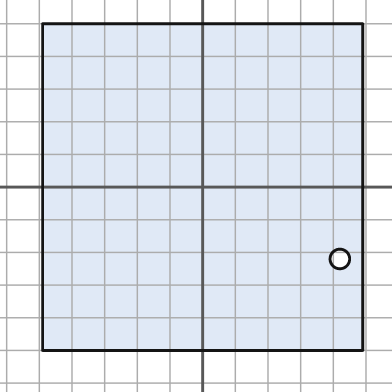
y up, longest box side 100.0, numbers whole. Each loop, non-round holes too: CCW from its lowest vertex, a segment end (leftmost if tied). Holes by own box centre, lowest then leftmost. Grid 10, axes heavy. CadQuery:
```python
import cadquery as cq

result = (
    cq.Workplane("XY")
    .moveTo(-49.0, -50.0)
    .lineTo(49.0, -50.0)
    .lineTo(49.0, 50.0)
    .lineTo(-49.0, 50.0)
    .close()
    .moveTo(42.0, -22.0)
    .circle(3.0)
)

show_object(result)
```